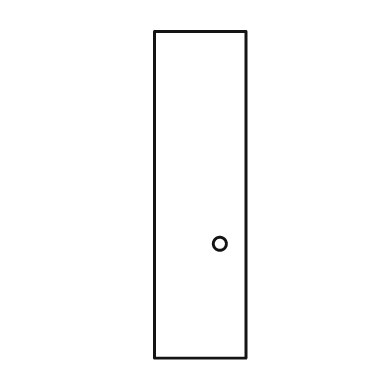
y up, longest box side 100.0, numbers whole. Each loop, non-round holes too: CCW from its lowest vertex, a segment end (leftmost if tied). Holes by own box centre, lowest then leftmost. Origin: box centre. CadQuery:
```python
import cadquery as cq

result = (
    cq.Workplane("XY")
    .moveTo(-14.0, -50.0)
    .lineTo(14.0, -50.0)
    .lineTo(14.0, 50.0)
    .lineTo(-14.0, 50.0)
    .close()
    .moveTo(6.0, -15.0)
    .circle(2.0)
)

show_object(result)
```